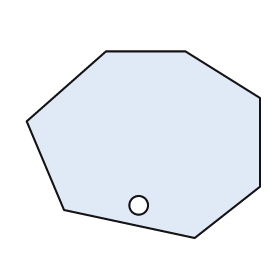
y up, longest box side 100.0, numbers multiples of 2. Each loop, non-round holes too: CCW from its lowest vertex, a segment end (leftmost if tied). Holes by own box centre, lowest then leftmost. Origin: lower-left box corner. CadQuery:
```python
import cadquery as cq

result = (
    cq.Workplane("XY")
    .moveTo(72.0, 0.0)
    .lineTo(100.0, 22.0)
    .lineTo(100.0, 60.0)
    .lineTo(68.0, 80.0)
    .lineTo(34.0, 80.0)
    .lineTo(0.0, 50.0)
    .lineTo(16.0, 12.0)
    .close()
    .moveTo(48.0, 14.0)
    .circle(4.0)
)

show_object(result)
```